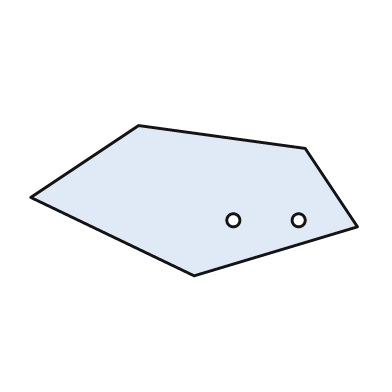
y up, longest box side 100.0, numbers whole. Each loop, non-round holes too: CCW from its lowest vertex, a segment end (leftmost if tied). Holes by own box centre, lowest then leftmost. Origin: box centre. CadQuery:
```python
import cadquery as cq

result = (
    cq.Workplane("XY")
    .moveTo(0.0, -23.0)
    .lineTo(50.0, -8.0)
    .lineTo(34.0, 16.0)
    .lineTo(-17.0, 23.0)
    .lineTo(-50.0, 1.0)
    .close()
    .moveTo(12.0, -6.0)
    .circle(2.0)
    .moveTo(32.0, -6.0)
    .circle(2.0)
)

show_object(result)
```